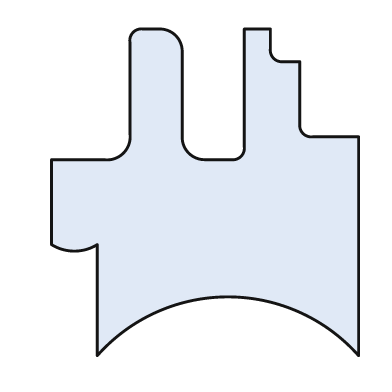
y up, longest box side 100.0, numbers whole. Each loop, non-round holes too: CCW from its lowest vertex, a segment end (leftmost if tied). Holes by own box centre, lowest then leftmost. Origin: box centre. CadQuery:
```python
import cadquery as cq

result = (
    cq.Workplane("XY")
    .moveTo(-33.0, -50.0)
    .threePointArc((7.0, -32.0), (47.0, -50.0))
    .lineTo(47.0, 17.0)
    .lineTo(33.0, 17.0)
    .threePointArc((30.0, 18.0), (29.0, 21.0))
    .lineTo(29.0, 40.0)
    .lineTo(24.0, 40.0)
    .threePointArc((21.0, 41.0), (20.0, 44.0))
    .lineTo(20.0, 50.0)
    .lineTo(12.0, 50.0)
    .lineTo(12.0, 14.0)
    .threePointArc((11.0, 11.0), (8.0, 10.0))
    .lineTo(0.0, 10.0)
    .threePointArc((-5.0, 12.0), (-7.0, 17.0))
    .lineTo(-7.0, 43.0)
    .threePointArc((-9.0, 48.0), (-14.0, 50.0))
    .lineTo(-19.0, 50.0)
    .threePointArc((-22.0, 49.0), (-23.0, 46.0))
    .lineTo(-23.0, 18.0)
    .threePointArc((-25.0, 12.0), (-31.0, 10.0))
    .lineTo(-47.0, 10.0)
    .lineTo(-47.0, -16.0)
    .threePointArc((-40.0, -18.0), (-33.0, -16.0))
    .close()
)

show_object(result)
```